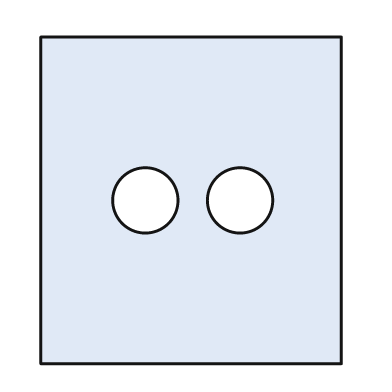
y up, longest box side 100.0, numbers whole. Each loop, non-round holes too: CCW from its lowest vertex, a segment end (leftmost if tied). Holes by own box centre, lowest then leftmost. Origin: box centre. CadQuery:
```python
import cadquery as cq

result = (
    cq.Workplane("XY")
    .moveTo(-46.0, -50.0)
    .lineTo(46.0, -50.0)
    .lineTo(46.0, 50.0)
    .lineTo(-46.0, 50.0)
    .close()
    .moveTo(-14.0, 0.0)
    .circle(10.0)
    .moveTo(15.0, 0.0)
    .circle(10.0)
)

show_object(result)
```